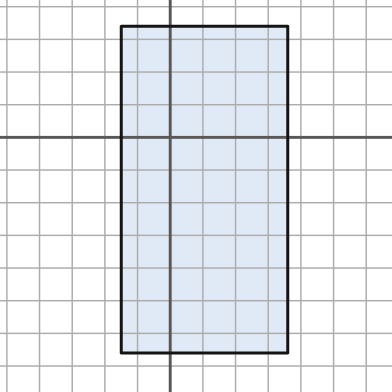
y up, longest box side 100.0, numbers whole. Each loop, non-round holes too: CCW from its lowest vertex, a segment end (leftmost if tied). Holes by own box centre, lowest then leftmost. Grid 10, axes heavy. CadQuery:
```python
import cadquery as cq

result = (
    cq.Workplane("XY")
    .moveTo(-15.0, -66.0)
    .lineTo(36.0, -66.0)
    .lineTo(36.0, 34.0)
    .lineTo(-15.0, 34.0)
    .close()
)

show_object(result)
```